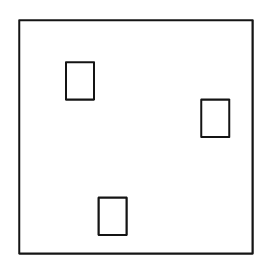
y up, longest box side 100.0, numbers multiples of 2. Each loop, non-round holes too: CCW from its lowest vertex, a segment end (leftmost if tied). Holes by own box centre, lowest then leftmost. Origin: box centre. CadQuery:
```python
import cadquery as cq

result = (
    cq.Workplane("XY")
    .moveTo(-50.0, -50.0)
    .lineTo(50.0, -50.0)
    .lineTo(50.0, 50.0)
    .lineTo(-50.0, 50.0)
    .close()
    .moveTo(-16.0, -42.0)
    .lineTo(-4.0, -42.0)
    .lineTo(-4.0, -26.0)
    .lineTo(-16.0, -26.0)
    .close()
    .moveTo(28.0, 0.0)
    .lineTo(40.0, 0.0)
    .lineTo(40.0, 16.0)
    .lineTo(28.0, 16.0)
    .close()
    .moveTo(-30.0, 16.0)
    .lineTo(-18.0, 16.0)
    .lineTo(-18.0, 32.0)
    .lineTo(-30.0, 32.0)
    .close()
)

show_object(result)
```